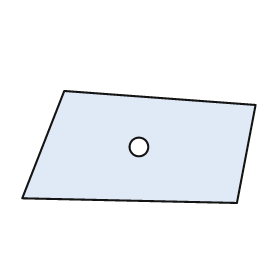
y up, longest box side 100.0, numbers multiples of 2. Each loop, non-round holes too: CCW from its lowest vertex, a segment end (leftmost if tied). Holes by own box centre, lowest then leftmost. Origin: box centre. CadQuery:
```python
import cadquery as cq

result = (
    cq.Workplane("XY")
    .moveTo(42.0, -24.0)
    .lineTo(50.0, 18.0)
    .lineTo(-32.0, 24.0)
    .lineTo(-50.0, -22.0)
    .close()
    .moveTo(0.0, 0.0)
    .circle(4.0)
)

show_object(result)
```